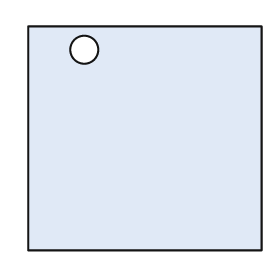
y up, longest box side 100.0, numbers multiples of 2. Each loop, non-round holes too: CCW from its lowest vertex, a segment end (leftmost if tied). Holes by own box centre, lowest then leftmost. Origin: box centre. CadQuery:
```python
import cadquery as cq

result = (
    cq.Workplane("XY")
    .moveTo(-50.0, -48.0)
    .lineTo(50.0, -48.0)
    .lineTo(50.0, 48.0)
    .lineTo(-50.0, 48.0)
    .close()
    .moveTo(-26.0, 38.0)
    .circle(6.0)
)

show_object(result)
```